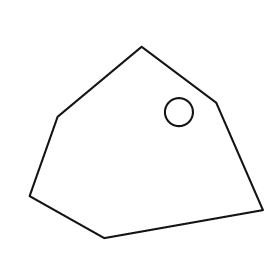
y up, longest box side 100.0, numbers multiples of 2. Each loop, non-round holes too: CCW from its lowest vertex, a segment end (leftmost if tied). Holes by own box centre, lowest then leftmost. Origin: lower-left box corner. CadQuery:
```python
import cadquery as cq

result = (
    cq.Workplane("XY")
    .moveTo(32.0, 0.0)
    .lineTo(100.0, 12.0)
    .lineTo(80.0, 58.0)
    .lineTo(48.0, 82.0)
    .lineTo(12.0, 52.0)
    .lineTo(0.0, 18.0)
    .close()
    .moveTo(64.0, 54.0)
    .circle(6.0)
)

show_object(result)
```